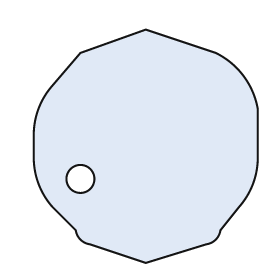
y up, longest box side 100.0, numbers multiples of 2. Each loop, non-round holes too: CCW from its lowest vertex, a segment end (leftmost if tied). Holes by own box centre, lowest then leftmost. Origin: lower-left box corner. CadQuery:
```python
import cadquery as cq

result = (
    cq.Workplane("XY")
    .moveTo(48.0, 0.0)
    .lineTo(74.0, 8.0)
    .threePointArc((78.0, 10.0), (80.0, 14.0))
    .lineTo(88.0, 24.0)
    .threePointArc((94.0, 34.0), (96.0, 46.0))
    .lineTo(96.0, 66.0)
    .threePointArc((90.0, 80.0), (78.0, 90.0))
    .lineTo(48.0, 100.0)
    .lineTo(20.0, 90.0)
    .lineTo(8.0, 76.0)
    .threePointArc((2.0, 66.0), (0.0, 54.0))
    .lineTo(0.0, 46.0)
    .threePointArc((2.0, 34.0), (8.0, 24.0))
    .lineTo(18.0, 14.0)
    .threePointArc((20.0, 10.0), (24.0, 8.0))
    .close()
    .moveTo(20.0, 36.0)
    .circle(6.0)
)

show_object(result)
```